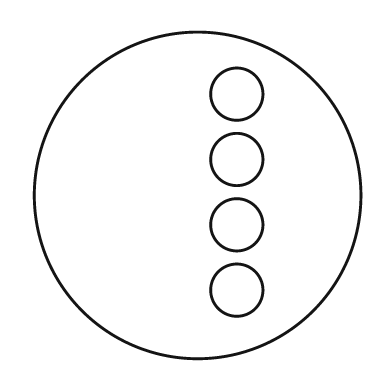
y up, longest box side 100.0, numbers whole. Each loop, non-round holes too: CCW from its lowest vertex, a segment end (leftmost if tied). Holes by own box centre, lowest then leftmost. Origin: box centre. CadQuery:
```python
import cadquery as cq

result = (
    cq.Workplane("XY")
    .moveTo(0.0, 0.0)
    .circle(50.0)
    .moveTo(12.0, -29.0)
    .circle(8.0)
    .moveTo(12.0, -9.0)
    .circle(8.0)
    .moveTo(12.0, 11.0)
    .circle(8.0)
    .moveTo(12.0, 31.0)
    .circle(8.0)
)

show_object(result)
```